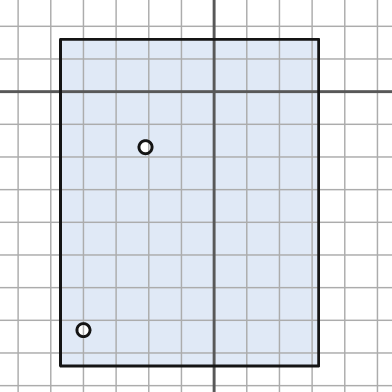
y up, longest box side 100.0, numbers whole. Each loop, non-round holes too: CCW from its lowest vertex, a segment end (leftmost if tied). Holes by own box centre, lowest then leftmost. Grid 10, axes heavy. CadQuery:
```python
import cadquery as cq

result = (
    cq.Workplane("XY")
    .moveTo(-47.0, -84.0)
    .lineTo(32.0, -84.0)
    .lineTo(32.0, 16.0)
    .lineTo(-47.0, 16.0)
    .close()
    .moveTo(-40.0, -73.0)
    .circle(2.0)
    .moveTo(-21.0, -17.0)
    .circle(2.0)
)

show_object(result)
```